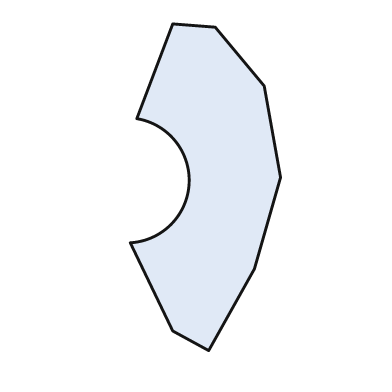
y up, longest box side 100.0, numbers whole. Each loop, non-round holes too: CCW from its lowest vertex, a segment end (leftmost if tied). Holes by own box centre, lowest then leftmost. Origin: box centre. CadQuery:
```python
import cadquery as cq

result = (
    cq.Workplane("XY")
    .moveTo(1.0, -50.0)
    .lineTo(15.0, -25.0)
    .lineTo(23.0, 3.0)
    .lineTo(18.0, 31.0)
    .lineTo(3.0, 49.0)
    .lineTo(-10.0, 50.0)
    .lineTo(-21.0, 21.0)
    .threePointArc((-5.0, 1.0), (-23.0, -17.0))
    .lineTo(-10.0, -44.0)
    .close()
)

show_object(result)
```